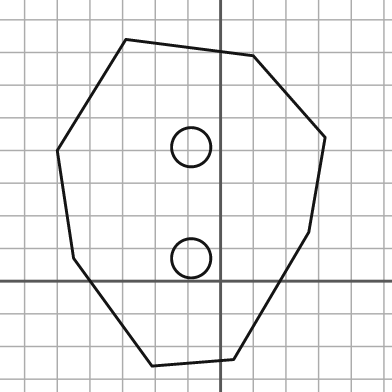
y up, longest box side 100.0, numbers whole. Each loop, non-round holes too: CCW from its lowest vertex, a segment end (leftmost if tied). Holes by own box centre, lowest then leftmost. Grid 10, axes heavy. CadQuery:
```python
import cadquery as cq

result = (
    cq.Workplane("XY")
    .moveTo(-21.0, -26.0)
    .lineTo(4.0, -24.0)
    .lineTo(27.0, 15.0)
    .lineTo(32.0, 44.0)
    .lineTo(10.0, 69.0)
    .lineTo(-29.0, 74.0)
    .lineTo(-50.0, 40.0)
    .lineTo(-45.0, 7.0)
    .close()
    .moveTo(-9.0, 7.0)
    .circle(6.0)
    .moveTo(-9.0, 41.0)
    .circle(6.0)
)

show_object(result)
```